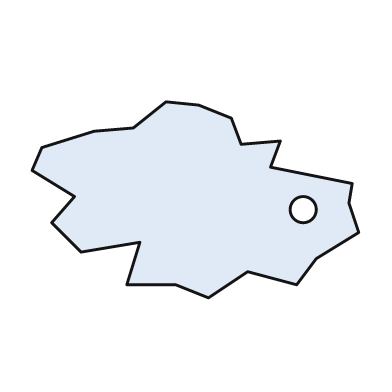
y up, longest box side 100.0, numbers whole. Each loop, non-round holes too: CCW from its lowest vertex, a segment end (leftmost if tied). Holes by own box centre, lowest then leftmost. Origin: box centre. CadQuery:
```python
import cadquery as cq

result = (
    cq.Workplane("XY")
    .moveTo(4.0, -30.0)
    .lineTo(16.0, -22.0)
    .lineTo(31.0, -26.0)
    .lineTo(37.0, -18.0)
    .lineTo(50.0, -10.0)
    .lineTo(47.0, -1.0)
    .lineTo(48.0, 5.0)
    .lineTo(23.0, 10.0)
    .lineTo(26.0, 18.0)
    .lineTo(14.0, 17.0)
    .lineTo(11.0, 25.0)
    .lineTo(1.0, 29.0)
    .lineTo(-9.0, 30.0)
    .lineTo(-19.0, 22.0)
    .lineTo(-31.0, 21.0)
    .lineTo(-47.0, 16.0)
    .lineTo(-50.0, 9.0)
    .lineTo(-37.0, 1.0)
    .lineTo(-44.0, -7.0)
    .lineTo(-35.0, -16.0)
    .lineTo(-17.0, -13.0)
    .lineTo(-21.0, -26.0)
    .lineTo(-6.0, -26.0)
    .close()
    .moveTo(33.0, -3.0)
    .circle(4.0)
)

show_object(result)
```